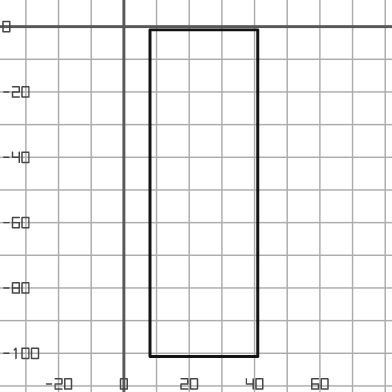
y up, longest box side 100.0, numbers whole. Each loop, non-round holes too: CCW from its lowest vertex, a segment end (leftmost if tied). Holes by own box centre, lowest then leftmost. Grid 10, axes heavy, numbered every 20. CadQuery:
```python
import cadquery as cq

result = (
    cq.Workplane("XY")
    .moveTo(8.0, -101.0)
    .lineTo(41.0, -101.0)
    .lineTo(41.0, -1.0)
    .lineTo(8.0, -1.0)
    .close()
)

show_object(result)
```